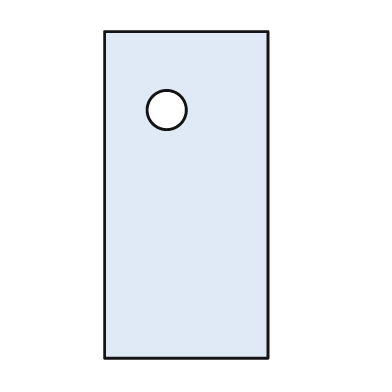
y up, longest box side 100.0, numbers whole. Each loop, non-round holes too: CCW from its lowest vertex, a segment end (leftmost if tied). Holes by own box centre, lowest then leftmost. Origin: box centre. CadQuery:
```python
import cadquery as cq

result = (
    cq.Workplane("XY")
    .moveTo(-25.0, -50.0)
    .lineTo(25.0, -50.0)
    .lineTo(25.0, 50.0)
    .lineTo(-25.0, 50.0)
    .close()
    .moveTo(-6.0, 26.0)
    .circle(6.0)
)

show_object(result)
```